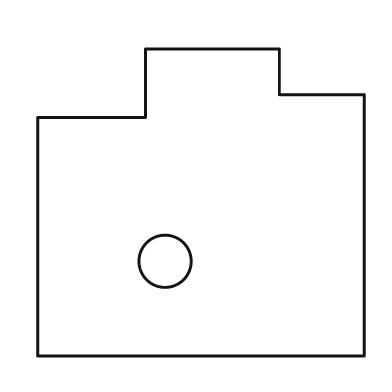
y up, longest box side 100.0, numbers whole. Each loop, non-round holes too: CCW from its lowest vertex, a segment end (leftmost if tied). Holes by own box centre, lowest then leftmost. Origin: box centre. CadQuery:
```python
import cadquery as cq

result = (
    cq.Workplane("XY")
    .moveTo(-50.0, -47.0)
    .lineTo(50.0, -47.0)
    .lineTo(50.0, 33.0)
    .lineTo(24.0, 33.0)
    .lineTo(24.0, 47.0)
    .lineTo(-17.0, 47.0)
    .lineTo(-17.0, 26.0)
    .lineTo(-50.0, 26.0)
    .close()
    .moveTo(-11.0, -18.0)
    .circle(8.0)
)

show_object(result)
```